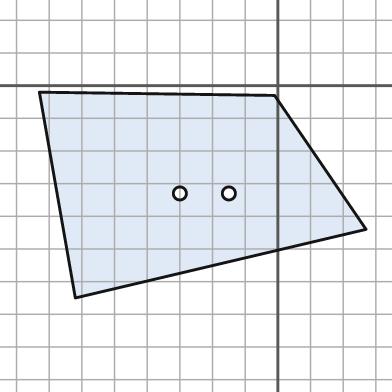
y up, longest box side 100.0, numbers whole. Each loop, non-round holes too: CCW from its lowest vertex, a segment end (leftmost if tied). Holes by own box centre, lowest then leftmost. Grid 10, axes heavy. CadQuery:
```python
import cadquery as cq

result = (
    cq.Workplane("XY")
    .moveTo(-62.0, -65.0)
    .lineTo(27.0, -44.0)
    .lineTo(-1.0, -3.0)
    .lineTo(-73.0, -2.0)
    .close()
    .moveTo(-30.0, -33.0)
    .circle(2.0)
    .moveTo(-15.0, -33.0)
    .circle(2.0)
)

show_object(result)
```